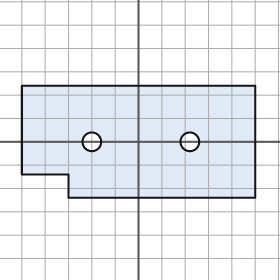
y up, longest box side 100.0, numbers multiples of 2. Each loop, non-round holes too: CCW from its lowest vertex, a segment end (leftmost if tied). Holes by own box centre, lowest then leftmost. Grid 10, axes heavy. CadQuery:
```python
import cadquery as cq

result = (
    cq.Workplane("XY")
    .moveTo(-30.0, -24.0)
    .lineTo(50.0, -24.0)
    .lineTo(50.0, 24.0)
    .lineTo(-50.0, 24.0)
    .lineTo(-50.0, -14.0)
    .lineTo(-30.0, -14.0)
    .close()
    .moveTo(-20.0, 0.0)
    .circle(4.0)
    .moveTo(22.0, 0.0)
    .circle(4.0)
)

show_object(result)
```